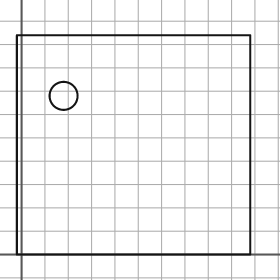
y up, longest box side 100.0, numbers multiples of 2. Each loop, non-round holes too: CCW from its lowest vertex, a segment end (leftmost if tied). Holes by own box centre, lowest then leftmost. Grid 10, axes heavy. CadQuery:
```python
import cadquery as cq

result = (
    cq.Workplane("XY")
    .moveTo(-2.0, 0.0)
    .lineTo(98.0, 0.0)
    .lineTo(98.0, 94.0)
    .lineTo(-2.0, 94.0)
    .close()
    .moveTo(18.0, 68.0)
    .circle(6.0)
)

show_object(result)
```